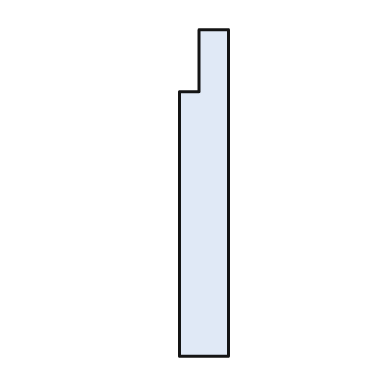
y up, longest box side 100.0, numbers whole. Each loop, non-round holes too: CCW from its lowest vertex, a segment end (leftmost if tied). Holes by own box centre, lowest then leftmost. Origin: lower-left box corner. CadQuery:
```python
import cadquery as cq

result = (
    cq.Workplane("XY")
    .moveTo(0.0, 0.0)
    .lineTo(15.0, 0.0)
    .lineTo(15.0, 100.0)
    .lineTo(6.0, 100.0)
    .lineTo(6.0, 81.0)
    .lineTo(0.0, 81.0)
    .close()
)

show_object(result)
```